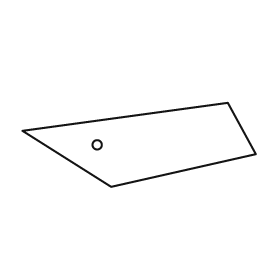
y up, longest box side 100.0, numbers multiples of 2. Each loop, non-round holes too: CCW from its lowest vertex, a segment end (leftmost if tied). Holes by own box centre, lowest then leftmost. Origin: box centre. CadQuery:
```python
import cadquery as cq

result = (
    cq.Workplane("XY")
    .moveTo(-12.0, -18.0)
    .lineTo(50.0, -4.0)
    .lineTo(38.0, 18.0)
    .lineTo(-50.0, 6.0)
    .close()
    .moveTo(-18.0, 0.0)
    .circle(2.0)
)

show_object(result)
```